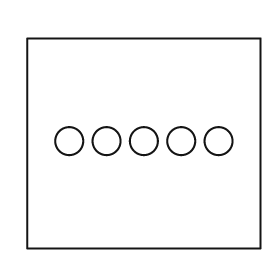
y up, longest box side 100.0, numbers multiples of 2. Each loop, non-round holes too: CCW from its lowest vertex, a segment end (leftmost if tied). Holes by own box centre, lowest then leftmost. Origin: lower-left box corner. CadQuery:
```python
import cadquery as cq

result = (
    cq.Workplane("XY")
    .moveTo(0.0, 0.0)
    .lineTo(100.0, 0.0)
    .lineTo(100.0, 90.0)
    .lineTo(0.0, 90.0)
    .close()
    .moveTo(18.0, 46.0)
    .circle(6.0)
    .moveTo(34.0, 46.0)
    .circle(6.0)
    .moveTo(50.0, 46.0)
    .circle(6.0)
    .moveTo(66.0, 46.0)
    .circle(6.0)
    .moveTo(82.0, 46.0)
    .circle(6.0)
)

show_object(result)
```